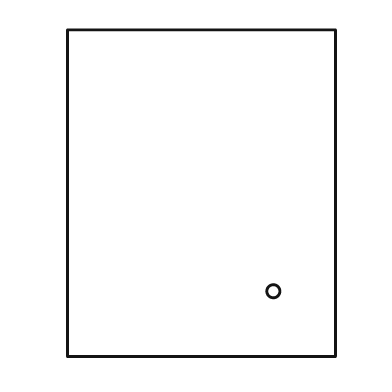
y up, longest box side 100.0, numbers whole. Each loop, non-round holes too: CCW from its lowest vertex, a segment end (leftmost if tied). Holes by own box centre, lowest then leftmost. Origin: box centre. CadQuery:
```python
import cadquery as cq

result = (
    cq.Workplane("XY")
    .moveTo(-41.0, -50.0)
    .lineTo(41.0, -50.0)
    .lineTo(41.0, 50.0)
    .lineTo(-41.0, 50.0)
    .close()
    .moveTo(22.0, -30.0)
    .circle(2.0)
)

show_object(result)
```